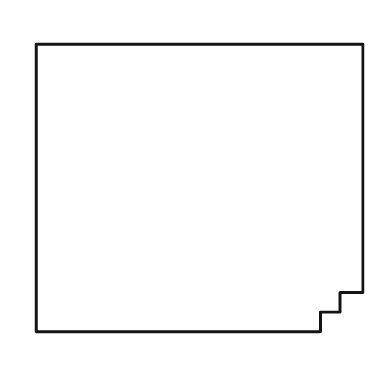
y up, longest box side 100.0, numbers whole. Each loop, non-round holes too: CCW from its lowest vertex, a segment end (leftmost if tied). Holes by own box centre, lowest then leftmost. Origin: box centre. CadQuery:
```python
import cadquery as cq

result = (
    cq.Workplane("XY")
    .moveTo(-50.0, -44.0)
    .lineTo(37.0, -44.0)
    .lineTo(37.0, -38.0)
    .lineTo(43.0, -38.0)
    .lineTo(43.0, -32.0)
    .lineTo(50.0, -32.0)
    .lineTo(50.0, 44.0)
    .lineTo(-50.0, 44.0)
    .close()
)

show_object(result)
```